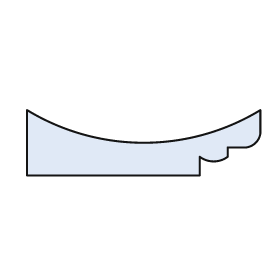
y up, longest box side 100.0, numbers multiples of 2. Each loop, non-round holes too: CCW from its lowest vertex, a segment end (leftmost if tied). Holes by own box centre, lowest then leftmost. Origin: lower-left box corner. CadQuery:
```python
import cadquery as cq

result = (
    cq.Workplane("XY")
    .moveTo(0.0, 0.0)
    .lineTo(74.0, 0.0)
    .lineTo(74.0, 8.0)
    .threePointArc((80.0, 6.0), (86.0, 8.0))
    .lineTo(86.0, 12.0)
    .lineTo(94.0, 12.0)
    .threePointArc((98.0, 14.0), (100.0, 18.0))
    .lineTo(100.0, 28.0)
    .threePointArc((50.0, 14.0), (0.0, 28.0))
    .close()
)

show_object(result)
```